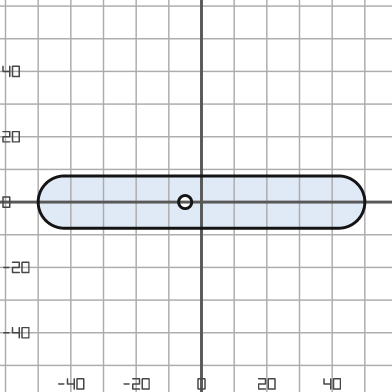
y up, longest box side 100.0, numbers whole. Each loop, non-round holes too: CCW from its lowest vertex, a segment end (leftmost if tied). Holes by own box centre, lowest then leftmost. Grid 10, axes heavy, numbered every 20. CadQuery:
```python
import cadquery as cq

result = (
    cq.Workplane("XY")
    .moveTo(-42.0, -8.0)
    .lineTo(42.0, -8.0)
    .threePointArc((50.0, 0.0), (42.0, 8.0))
    .lineTo(-42.0, 8.0)
    .threePointArc((-50.0, 0.0), (-42.0, -8.0))
    .close()
    .moveTo(-5.0, 0.0)
    .circle(2.0)
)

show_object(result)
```